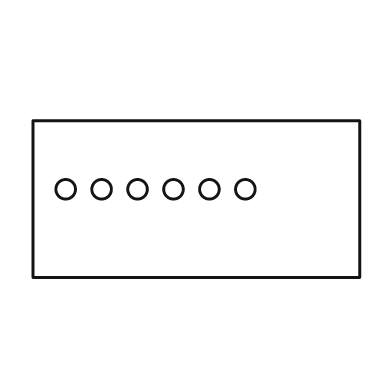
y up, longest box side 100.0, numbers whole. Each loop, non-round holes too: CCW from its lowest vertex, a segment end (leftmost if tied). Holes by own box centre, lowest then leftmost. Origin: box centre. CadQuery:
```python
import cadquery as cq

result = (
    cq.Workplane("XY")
    .moveTo(-50.0, -24.0)
    .lineTo(50.0, -24.0)
    .lineTo(50.0, 24.0)
    .lineTo(-50.0, 24.0)
    .close()
    .moveTo(-40.0, 3.0)
    .circle(3.0)
    .moveTo(-29.0, 3.0)
    .circle(3.0)
    .moveTo(-18.0, 3.0)
    .circle(3.0)
    .moveTo(-7.0, 3.0)
    .circle(3.0)
    .moveTo(4.0, 3.0)
    .circle(3.0)
    .moveTo(15.0, 3.0)
    .circle(3.0)
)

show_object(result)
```